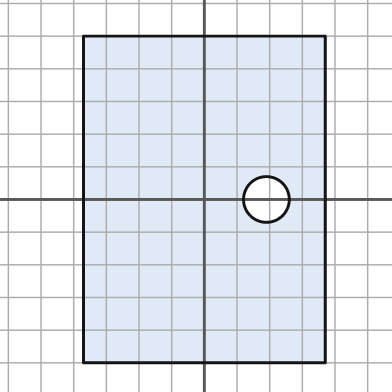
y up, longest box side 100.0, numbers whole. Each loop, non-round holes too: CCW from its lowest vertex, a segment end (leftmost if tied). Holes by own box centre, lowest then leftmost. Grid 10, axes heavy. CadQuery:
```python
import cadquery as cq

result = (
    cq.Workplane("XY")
    .moveTo(-37.0, -50.0)
    .lineTo(37.0, -50.0)
    .lineTo(37.0, 50.0)
    .lineTo(-37.0, 50.0)
    .close()
    .moveTo(19.0, 0.0)
    .circle(7.0)
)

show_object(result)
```